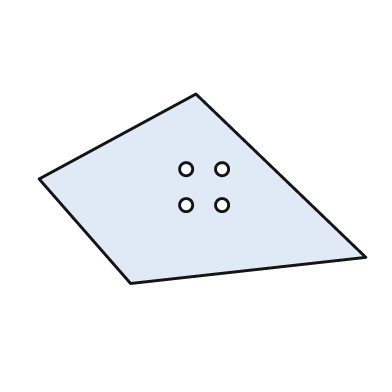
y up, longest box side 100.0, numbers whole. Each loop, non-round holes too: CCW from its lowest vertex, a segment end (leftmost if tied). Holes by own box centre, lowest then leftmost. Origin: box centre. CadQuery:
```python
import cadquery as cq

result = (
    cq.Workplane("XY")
    .moveTo(-22.0, -29.0)
    .lineTo(50.0, -21.0)
    .lineTo(-2.0, 29.0)
    .lineTo(-50.0, 3.0)
    .close()
    .moveTo(-5.0, -5.0)
    .circle(2.0)
    .moveTo(6.0, -5.0)
    .circle(2.0)
    .moveTo(-5.0, 6.0)
    .circle(2.0)
    .moveTo(6.0, 6.0)
    .circle(2.0)
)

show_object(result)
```